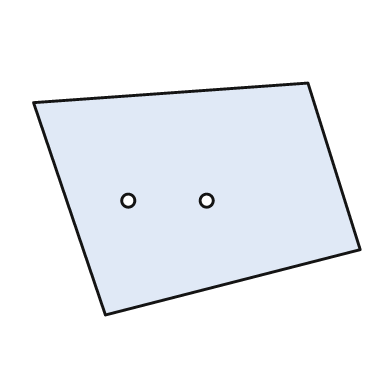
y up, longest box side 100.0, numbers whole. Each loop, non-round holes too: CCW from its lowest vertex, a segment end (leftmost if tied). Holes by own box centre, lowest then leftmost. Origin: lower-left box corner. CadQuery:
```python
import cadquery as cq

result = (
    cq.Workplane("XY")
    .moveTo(22.0, 0.0)
    .lineTo(100.0, 20.0)
    .lineTo(84.0, 71.0)
    .lineTo(0.0, 65.0)
    .close()
    .moveTo(29.0, 35.0)
    .circle(2.0)
    .moveTo(53.0, 35.0)
    .circle(2.0)
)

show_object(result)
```